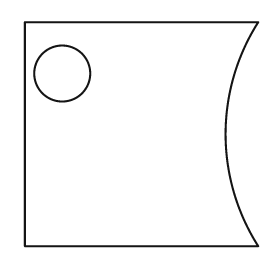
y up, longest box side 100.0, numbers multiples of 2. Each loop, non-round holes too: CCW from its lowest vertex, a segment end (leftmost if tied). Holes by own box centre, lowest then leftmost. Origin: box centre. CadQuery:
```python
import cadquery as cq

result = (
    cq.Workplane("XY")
    .moveTo(-50.0, -48.0)
    .lineTo(50.0, -48.0)
    .threePointArc((36.0, 0.0), (50.0, 48.0))
    .lineTo(-50.0, 48.0)
    .close()
    .moveTo(-34.0, 26.0)
    .circle(12.0)
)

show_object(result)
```